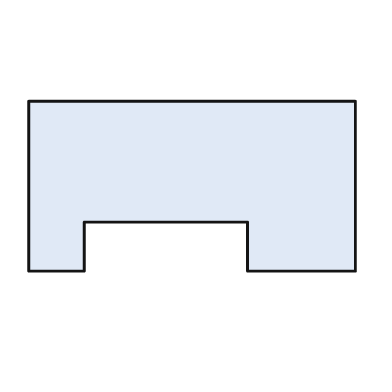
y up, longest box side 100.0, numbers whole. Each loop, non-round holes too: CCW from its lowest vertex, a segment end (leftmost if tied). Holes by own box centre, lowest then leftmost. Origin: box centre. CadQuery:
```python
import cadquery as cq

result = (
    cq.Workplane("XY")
    .moveTo(-50.0, -26.0)
    .lineTo(-33.0, -26.0)
    .lineTo(-33.0, -11.0)
    .lineTo(17.0, -11.0)
    .lineTo(17.0, -26.0)
    .lineTo(50.0, -26.0)
    .lineTo(50.0, 26.0)
    .lineTo(-50.0, 26.0)
    .close()
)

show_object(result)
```